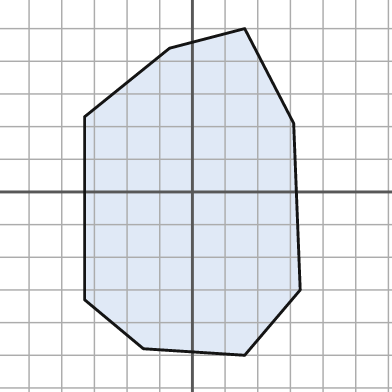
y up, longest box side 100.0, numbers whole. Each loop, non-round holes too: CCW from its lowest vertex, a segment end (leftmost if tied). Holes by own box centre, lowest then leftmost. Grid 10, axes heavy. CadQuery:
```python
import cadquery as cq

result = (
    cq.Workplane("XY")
    .moveTo(16.0, -50.0)
    .lineTo(33.0, -30.0)
    .lineTo(31.0, 21.0)
    .lineTo(16.0, 50.0)
    .lineTo(-7.0, 44.0)
    .lineTo(-33.0, 23.0)
    .lineTo(-33.0, -33.0)
    .lineTo(-15.0, -48.0)
    .close()
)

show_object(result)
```